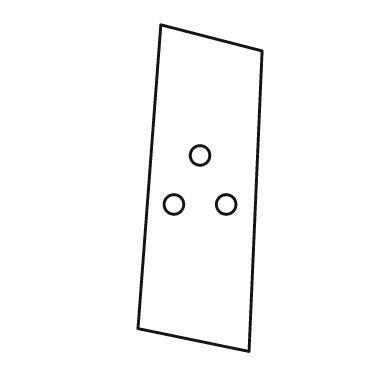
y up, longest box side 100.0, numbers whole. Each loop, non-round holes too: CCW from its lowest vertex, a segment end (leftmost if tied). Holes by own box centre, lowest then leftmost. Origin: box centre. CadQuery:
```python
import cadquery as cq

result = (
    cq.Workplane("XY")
    .moveTo(15.0, -50.0)
    .lineTo(19.0, 42.0)
    .lineTo(-12.0, 50.0)
    .lineTo(-19.0, -43.0)
    .close()
    .moveTo(-8.0, -5.0)
    .circle(3.0)
    .moveTo(8.0, -5.0)
    .circle(3.0)
    .moveTo(0.0, 10.0)
    .circle(3.0)
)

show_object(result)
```